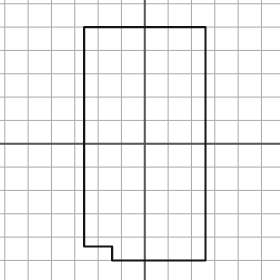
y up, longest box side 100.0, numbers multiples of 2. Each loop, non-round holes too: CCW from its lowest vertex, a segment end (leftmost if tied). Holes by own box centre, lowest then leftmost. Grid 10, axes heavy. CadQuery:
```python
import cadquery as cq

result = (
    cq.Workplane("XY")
    .moveTo(-14.0, -50.0)
    .lineTo(26.0, -50.0)
    .lineTo(26.0, 50.0)
    .lineTo(-26.0, 50.0)
    .lineTo(-26.0, -44.0)
    .lineTo(-14.0, -44.0)
    .close()
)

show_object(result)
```